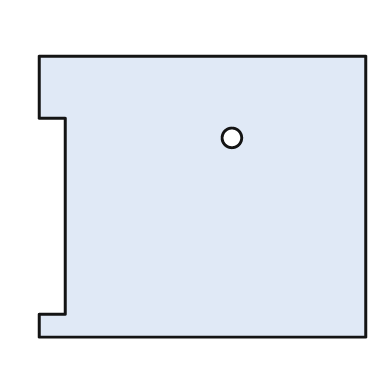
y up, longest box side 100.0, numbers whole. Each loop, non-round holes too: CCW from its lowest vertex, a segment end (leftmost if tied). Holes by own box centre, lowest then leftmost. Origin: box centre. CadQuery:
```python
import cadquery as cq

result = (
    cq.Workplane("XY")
    .moveTo(-50.0, -43.0)
    .lineTo(50.0, -43.0)
    .lineTo(50.0, 43.0)
    .lineTo(-50.0, 43.0)
    .lineTo(-50.0, 24.0)
    .lineTo(-42.0, 24.0)
    .lineTo(-42.0, -36.0)
    .lineTo(-50.0, -36.0)
    .close()
    .moveTo(9.0, 18.0)
    .circle(3.0)
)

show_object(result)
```